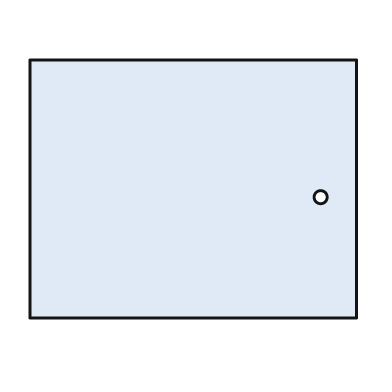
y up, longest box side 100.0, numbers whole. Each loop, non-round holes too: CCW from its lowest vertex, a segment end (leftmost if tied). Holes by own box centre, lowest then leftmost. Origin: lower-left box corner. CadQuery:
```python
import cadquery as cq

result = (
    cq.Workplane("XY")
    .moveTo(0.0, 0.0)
    .lineTo(100.0, 0.0)
    .lineTo(100.0, 79.0)
    .lineTo(0.0, 79.0)
    .close()
    .moveTo(89.0, 37.0)
    .circle(2.0)
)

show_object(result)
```